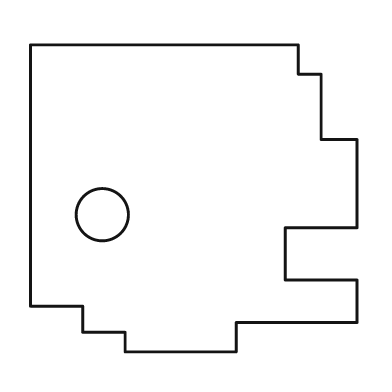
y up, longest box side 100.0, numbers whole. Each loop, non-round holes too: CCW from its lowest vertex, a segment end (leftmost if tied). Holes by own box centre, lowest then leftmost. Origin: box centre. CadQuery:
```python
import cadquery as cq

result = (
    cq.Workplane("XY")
    .moveTo(-21.0, -47.0)
    .lineTo(13.0, -47.0)
    .lineTo(13.0, -38.0)
    .lineTo(50.0, -38.0)
    .lineTo(50.0, -25.0)
    .lineTo(28.0, -25.0)
    .lineTo(28.0, -9.0)
    .lineTo(50.0, -9.0)
    .lineTo(50.0, 18.0)
    .lineTo(39.0, 18.0)
    .lineTo(39.0, 38.0)
    .lineTo(32.0, 38.0)
    .lineTo(32.0, 47.0)
    .lineTo(-50.0, 47.0)
    .lineTo(-50.0, -33.0)
    .lineTo(-34.0, -33.0)
    .lineTo(-34.0, -41.0)
    .lineTo(-21.0, -41.0)
    .close()
    .moveTo(-28.0, -5.0)
    .circle(8.0)
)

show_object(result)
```